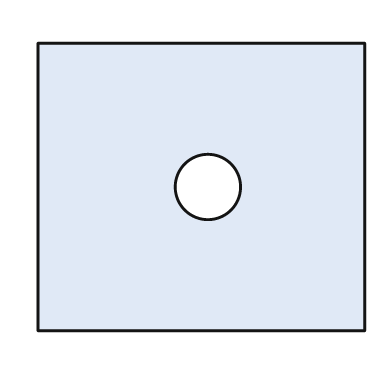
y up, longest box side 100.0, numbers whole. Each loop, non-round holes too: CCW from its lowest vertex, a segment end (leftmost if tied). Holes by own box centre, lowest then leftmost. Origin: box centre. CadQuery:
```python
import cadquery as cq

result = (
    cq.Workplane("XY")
    .moveTo(-50.0, -44.0)
    .lineTo(50.0, -44.0)
    .lineTo(50.0, 44.0)
    .lineTo(-50.0, 44.0)
    .close()
    .moveTo(2.0, 0.0)
    .circle(10.0)
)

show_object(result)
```